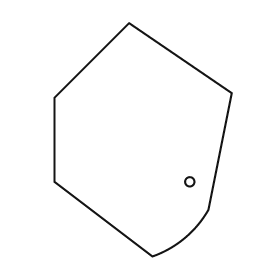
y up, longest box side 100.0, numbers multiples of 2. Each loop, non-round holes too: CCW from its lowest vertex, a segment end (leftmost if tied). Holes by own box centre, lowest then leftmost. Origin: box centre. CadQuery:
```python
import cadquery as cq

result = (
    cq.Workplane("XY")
    .moveTo(4.0, -50.0)
    .threePointArc((18.0, -42.0), (28.0, -30.0))
    .lineTo(38.0, 20.0)
    .lineTo(-6.0, 50.0)
    .lineTo(-38.0, 18.0)
    .lineTo(-38.0, -18.0)
    .close()
    .moveTo(20.0, -18.0)
    .circle(2.0)
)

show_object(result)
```